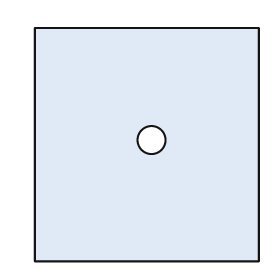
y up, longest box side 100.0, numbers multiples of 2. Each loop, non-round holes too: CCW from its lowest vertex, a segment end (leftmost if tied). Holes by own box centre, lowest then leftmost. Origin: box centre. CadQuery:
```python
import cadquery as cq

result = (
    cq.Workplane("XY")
    .moveTo(-48.0, -50.0)
    .lineTo(48.0, -50.0)
    .lineTo(48.0, 50.0)
    .lineTo(-48.0, 50.0)
    .close()
    .moveTo(2.0, 2.0)
    .circle(6.0)
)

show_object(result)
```